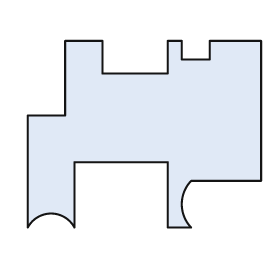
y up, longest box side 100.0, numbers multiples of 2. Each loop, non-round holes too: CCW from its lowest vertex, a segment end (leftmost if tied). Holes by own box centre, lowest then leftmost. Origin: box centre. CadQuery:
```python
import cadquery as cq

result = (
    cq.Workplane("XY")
    .moveTo(-50.0, -40.0)
    .threePointArc((-40.0, -34.0), (-30.0, -40.0))
    .lineTo(-30.0, -12.0)
    .lineTo(10.0, -12.0)
    .lineTo(10.0, -40.0)
    .lineTo(20.0, -40.0)
    .threePointArc((16.0, -30.0), (20.0, -20.0))
    .lineTo(50.0, -20.0)
    .lineTo(50.0, 40.0)
    .lineTo(28.0, 40.0)
    .lineTo(28.0, 32.0)
    .lineTo(16.0, 32.0)
    .lineTo(16.0, 40.0)
    .lineTo(10.0, 40.0)
    .lineTo(10.0, 26.0)
    .lineTo(-18.0, 26.0)
    .lineTo(-18.0, 40.0)
    .lineTo(-34.0, 40.0)
    .lineTo(-34.0, 8.0)
    .lineTo(-50.0, 8.0)
    .close()
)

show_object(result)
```